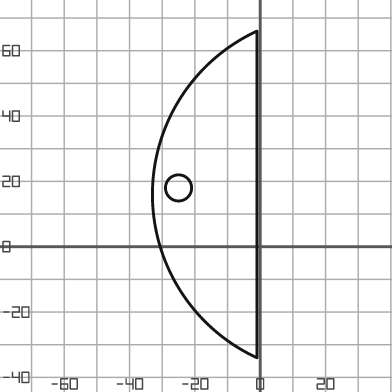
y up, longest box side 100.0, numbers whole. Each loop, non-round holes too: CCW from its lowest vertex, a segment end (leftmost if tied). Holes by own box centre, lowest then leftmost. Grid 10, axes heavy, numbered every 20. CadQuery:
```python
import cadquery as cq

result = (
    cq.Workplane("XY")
    .moveTo(-1.0, -34.0)
    .lineTo(-1.0, 66.0)
    .threePointArc((-33.0, 16.0), (-1.0, -34.0))
    .close()
    .moveTo(-25.0, 18.0)
    .circle(4.0)
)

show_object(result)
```